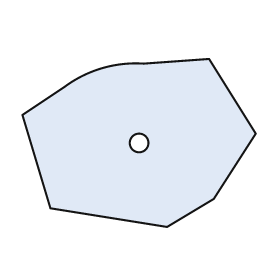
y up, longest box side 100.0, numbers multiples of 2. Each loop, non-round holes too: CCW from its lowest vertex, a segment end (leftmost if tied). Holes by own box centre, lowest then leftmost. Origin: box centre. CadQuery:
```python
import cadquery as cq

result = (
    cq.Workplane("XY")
    .moveTo(12.0, -36.0)
    .lineTo(32.0, -24.0)
    .lineTo(50.0, 4.0)
    .lineTo(30.0, 36.0)
    .lineTo(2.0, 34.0)
    .threePointArc((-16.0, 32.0), (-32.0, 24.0))
    .lineTo(-50.0, 12.0)
    .lineTo(-38.0, -28.0)
    .close()
    .moveTo(0.0, 0.0)
    .circle(4.0)
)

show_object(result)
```